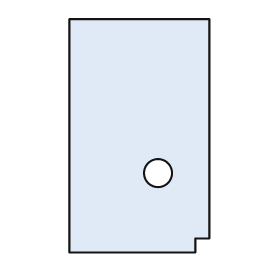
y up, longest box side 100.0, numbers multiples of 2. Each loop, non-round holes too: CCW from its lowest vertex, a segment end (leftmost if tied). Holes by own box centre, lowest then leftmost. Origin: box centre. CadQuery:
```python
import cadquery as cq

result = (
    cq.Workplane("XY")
    .moveTo(-30.0, -50.0)
    .lineTo(24.0, -50.0)
    .lineTo(24.0, -44.0)
    .lineTo(30.0, -44.0)
    .lineTo(30.0, 50.0)
    .lineTo(-30.0, 50.0)
    .close()
    .moveTo(8.0, -16.0)
    .circle(6.0)
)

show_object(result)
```